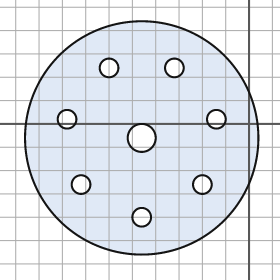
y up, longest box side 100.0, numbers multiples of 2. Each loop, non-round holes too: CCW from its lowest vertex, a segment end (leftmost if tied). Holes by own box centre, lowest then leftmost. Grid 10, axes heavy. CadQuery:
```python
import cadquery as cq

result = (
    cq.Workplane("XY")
    .moveTo(-46.0, -6.0)
    .circle(50.0)
    .moveTo(-46.0, -40.0)
    .circle(4.0)
    .moveTo(-72.0, -26.0)
    .circle(4.0)
    .moveTo(-20.0, -26.0)
    .circle(4.0)
    .moveTo(-46.0, -6.0)
    .circle(6.0)
    .moveTo(-78.0, 2.0)
    .circle(4.0)
    .moveTo(-14.0, 2.0)
    .circle(4.0)
    .moveTo(-60.0, 24.0)
    .circle(4.0)
    .moveTo(-32.0, 24.0)
    .circle(4.0)
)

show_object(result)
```